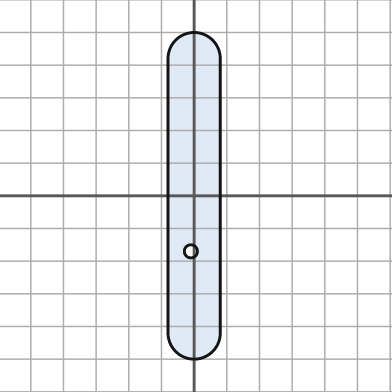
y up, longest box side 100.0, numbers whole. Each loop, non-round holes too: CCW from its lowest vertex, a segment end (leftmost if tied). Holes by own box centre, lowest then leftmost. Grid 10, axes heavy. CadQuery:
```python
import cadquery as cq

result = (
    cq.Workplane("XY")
    .moveTo(-8.0, -42.0)
    .threePointArc((0.0, -50.0), (8.0, -42.0))
    .lineTo(8.0, 42.0)
    .threePointArc((0.0, 50.0), (-8.0, 42.0))
    .close()
    .moveTo(-1.0, -17.0)
    .circle(2.0)
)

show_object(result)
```